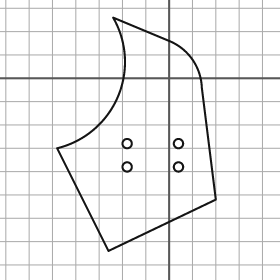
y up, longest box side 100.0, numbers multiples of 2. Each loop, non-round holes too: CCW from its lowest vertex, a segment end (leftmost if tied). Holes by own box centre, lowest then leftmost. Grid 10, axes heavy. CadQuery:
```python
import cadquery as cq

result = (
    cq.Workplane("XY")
    .moveTo(-26.0, -74.0)
    .lineTo(20.0, -52.0)
    .lineTo(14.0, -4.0)
    .threePointArc((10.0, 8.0), (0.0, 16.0))
    .lineTo(-24.0, 26.0)
    .threePointArc((-22.0, -8.0), (-48.0, -30.0))
    .close()
    .moveTo(-18.0, -38.0)
    .circle(2.0)
    .moveTo(4.0, -38.0)
    .circle(2.0)
    .moveTo(-18.0, -28.0)
    .circle(2.0)
    .moveTo(4.0, -28.0)
    .circle(2.0)
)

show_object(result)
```